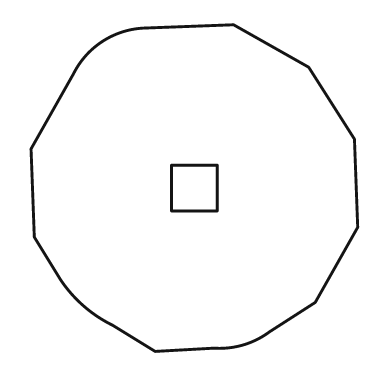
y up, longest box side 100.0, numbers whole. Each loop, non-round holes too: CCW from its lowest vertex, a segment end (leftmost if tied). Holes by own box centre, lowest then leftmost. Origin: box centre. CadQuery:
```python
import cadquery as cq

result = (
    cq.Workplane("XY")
    .moveTo(-12.0, -50.0)
    .lineTo(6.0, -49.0)
    .threePointArc((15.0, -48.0), (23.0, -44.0))
    .lineTo(37.0, -35.0)
    .lineTo(50.0, -12.0)
    .lineTo(49.0, 15.0)
    .lineTo(35.0, 37.0)
    .lineTo(12.0, 50.0)
    .lineTo(-15.0, 49.0)
    .threePointArc((-28.0, 45.0), (-37.0, 35.0))
    .lineTo(-50.0, 12.0)
    .lineTo(-49.0, -15.0)
    .lineTo(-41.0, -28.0)
    .threePointArc((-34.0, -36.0), (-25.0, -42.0))
    .close()
    .moveTo(-7.0, -7.0)
    .lineTo(7.0, -7.0)
    .lineTo(7.0, 7.0)
    .lineTo(-7.0, 7.0)
    .close()
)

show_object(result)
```